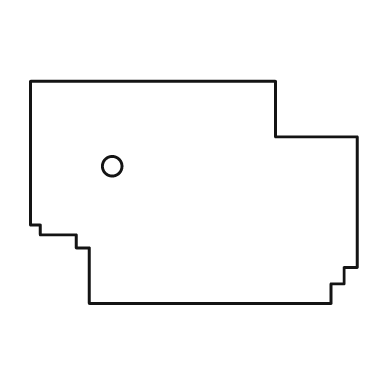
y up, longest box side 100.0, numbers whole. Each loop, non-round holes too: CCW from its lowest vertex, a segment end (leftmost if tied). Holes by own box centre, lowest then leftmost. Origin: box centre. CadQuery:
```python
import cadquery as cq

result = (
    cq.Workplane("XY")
    .moveTo(-32.0, -34.0)
    .lineTo(42.0, -34.0)
    .lineTo(42.0, -28.0)
    .lineTo(46.0, -28.0)
    .lineTo(46.0, -23.0)
    .lineTo(50.0, -23.0)
    .lineTo(50.0, 17.0)
    .lineTo(25.0, 17.0)
    .lineTo(25.0, 34.0)
    .lineTo(-50.0, 34.0)
    .lineTo(-50.0, -10.0)
    .lineTo(-47.0, -10.0)
    .lineTo(-47.0, -13.0)
    .lineTo(-36.0, -13.0)
    .lineTo(-36.0, -17.0)
    .lineTo(-32.0, -17.0)
    .close()
    .moveTo(-25.0, 8.0)
    .circle(3.0)
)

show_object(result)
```